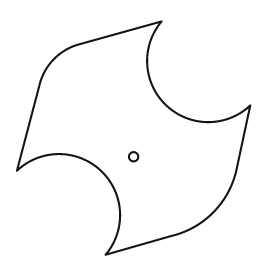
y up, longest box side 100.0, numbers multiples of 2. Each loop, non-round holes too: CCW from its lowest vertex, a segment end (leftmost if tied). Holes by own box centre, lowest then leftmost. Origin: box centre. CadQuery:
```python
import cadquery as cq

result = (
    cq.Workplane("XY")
    .moveTo(-12.0, -50.0)
    .lineTo(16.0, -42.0)
    .threePointArc((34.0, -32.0), (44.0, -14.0))
    .lineTo(50.0, 14.0)
    .threePointArc((14.0, 14.0), (12.0, 50.0))
    .lineTo(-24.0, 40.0)
    .threePointArc((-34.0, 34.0), (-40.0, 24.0))
    .lineTo(-50.0, -14.0)
    .threePointArc((-14.0, -14.0), (-12.0, -50.0))
    .close()
    .moveTo(0.0, -8.0)
    .circle(2.0)
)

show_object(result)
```